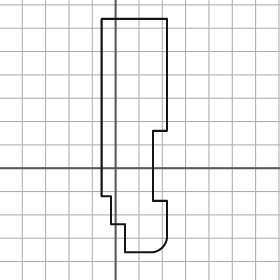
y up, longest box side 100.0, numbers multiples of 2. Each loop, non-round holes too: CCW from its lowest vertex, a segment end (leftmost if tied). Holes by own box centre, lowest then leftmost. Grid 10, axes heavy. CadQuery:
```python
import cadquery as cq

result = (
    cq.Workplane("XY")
    .moveTo(4.0, -36.0)
    .lineTo(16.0, -36.0)
    .threePointArc((20.0, -34.0), (22.0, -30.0))
    .lineTo(22.0, -14.0)
    .lineTo(16.0, -14.0)
    .lineTo(16.0, 16.0)
    .lineTo(22.0, 16.0)
    .lineTo(22.0, 64.0)
    .lineTo(-6.0, 64.0)
    .lineTo(-6.0, -12.0)
    .lineTo(-2.0, -12.0)
    .lineTo(-2.0, -24.0)
    .lineTo(4.0, -24.0)
    .close()
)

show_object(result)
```